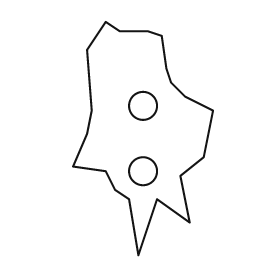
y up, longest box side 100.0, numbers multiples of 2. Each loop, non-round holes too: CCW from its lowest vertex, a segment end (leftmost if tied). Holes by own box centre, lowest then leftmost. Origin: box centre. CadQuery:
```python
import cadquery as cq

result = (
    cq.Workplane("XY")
    .moveTo(-2.0, -50.0)
    .lineTo(6.0, -26.0)
    .lineTo(20.0, -36.0)
    .lineTo(16.0, -16.0)
    .lineTo(26.0, -8.0)
    .lineTo(30.0, 12.0)
    .lineTo(18.0, 18.0)
    .lineTo(12.0, 24.0)
    .lineTo(10.0, 30.0)
    .lineTo(8.0, 44.0)
    .lineTo(2.0, 46.0)
    .lineTo(-10.0, 46.0)
    .lineTo(-16.0, 50.0)
    .lineTo(-24.0, 38.0)
    .lineTo(-22.0, 12.0)
    .lineTo(-24.0, 2.0)
    .lineTo(-30.0, -12.0)
    .lineTo(-16.0, -14.0)
    .lineTo(-12.0, -22.0)
    .lineTo(-6.0, -26.0)
    .close()
    .moveTo(0.0, -14.0)
    .circle(6.0)
    .moveTo(0.0, 14.0)
    .circle(6.0)
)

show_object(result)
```